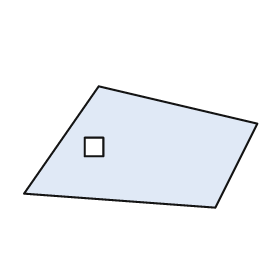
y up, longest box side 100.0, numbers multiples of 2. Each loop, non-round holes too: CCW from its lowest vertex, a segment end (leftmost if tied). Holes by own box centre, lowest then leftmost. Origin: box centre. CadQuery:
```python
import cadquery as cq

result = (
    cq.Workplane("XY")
    .moveTo(32.0, -26.0)
    .lineTo(50.0, 10.0)
    .lineTo(-18.0, 26.0)
    .lineTo(-50.0, -20.0)
    .close()
    .moveTo(-24.0, -4.0)
    .lineTo(-16.0, -4.0)
    .lineTo(-16.0, 4.0)
    .lineTo(-24.0, 4.0)
    .close()
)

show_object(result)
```